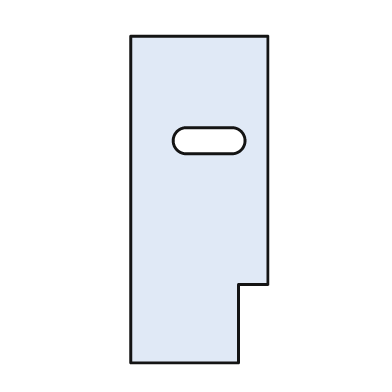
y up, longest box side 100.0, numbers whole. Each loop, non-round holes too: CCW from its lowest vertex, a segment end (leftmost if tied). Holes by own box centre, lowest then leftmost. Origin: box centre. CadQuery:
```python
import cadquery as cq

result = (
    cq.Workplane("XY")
    .moveTo(-21.0, -50.0)
    .lineTo(12.0, -50.0)
    .lineTo(12.0, -26.0)
    .lineTo(21.0, -26.0)
    .lineTo(21.0, 50.0)
    .lineTo(-21.0, 50.0)
    .close()
    .moveTo(-4.0, 14.0)
    .lineTo(10.0, 14.0)
    .threePointArc((14.0, 18.0), (10.0, 22.0))
    .lineTo(-4.0, 22.0)
    .threePointArc((-8.0, 18.0), (-4.0, 14.0))
    .close()
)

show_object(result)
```